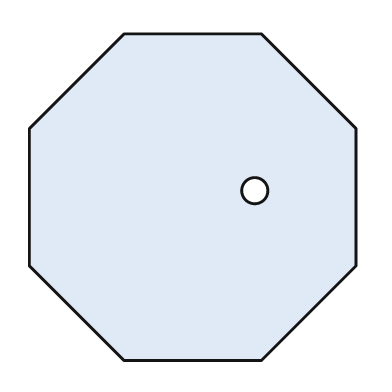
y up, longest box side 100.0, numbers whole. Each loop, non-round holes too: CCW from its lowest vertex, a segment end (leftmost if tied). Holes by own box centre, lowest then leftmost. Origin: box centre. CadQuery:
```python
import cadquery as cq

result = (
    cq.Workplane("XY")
    .moveTo(-21.0, -50.0)
    .lineTo(21.0, -50.0)
    .lineTo(50.0, -21.0)
    .lineTo(50.0, 21.0)
    .lineTo(21.0, 50.0)
    .lineTo(-21.0, 50.0)
    .lineTo(-50.0, 21.0)
    .lineTo(-50.0, -21.0)
    .close()
    .moveTo(19.0, 2.0)
    .circle(4.0)
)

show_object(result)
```